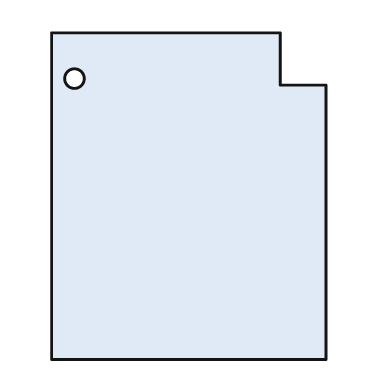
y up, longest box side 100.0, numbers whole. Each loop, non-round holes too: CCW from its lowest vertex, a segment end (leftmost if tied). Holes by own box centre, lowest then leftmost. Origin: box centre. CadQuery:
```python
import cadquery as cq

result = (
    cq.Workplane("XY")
    .moveTo(-42.0, -50.0)
    .lineTo(42.0, -50.0)
    .lineTo(42.0, 34.0)
    .lineTo(28.0, 34.0)
    .lineTo(28.0, 50.0)
    .lineTo(-42.0, 50.0)
    .close()
    .moveTo(-35.0, 36.0)
    .circle(3.0)
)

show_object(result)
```